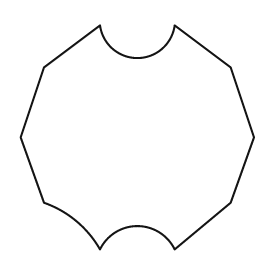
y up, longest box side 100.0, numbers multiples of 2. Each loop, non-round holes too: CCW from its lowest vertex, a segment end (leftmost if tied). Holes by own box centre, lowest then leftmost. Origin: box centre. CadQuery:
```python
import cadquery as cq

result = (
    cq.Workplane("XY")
    .moveTo(-16.0, -48.0)
    .threePointArc((0.0, -38.0), (16.0, -48.0))
    .lineTo(40.0, -28.0)
    .lineTo(50.0, 0.0)
    .lineTo(40.0, 30.0)
    .lineTo(16.0, 48.0)
    .threePointArc((0.0, 34.0), (-16.0, 48.0))
    .lineTo(-40.0, 30.0)
    .lineTo(-50.0, 0.0)
    .lineTo(-40.0, -28.0)
    .threePointArc((-26.0, -36.0), (-16.0, -48.0))
    .close()
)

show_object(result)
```